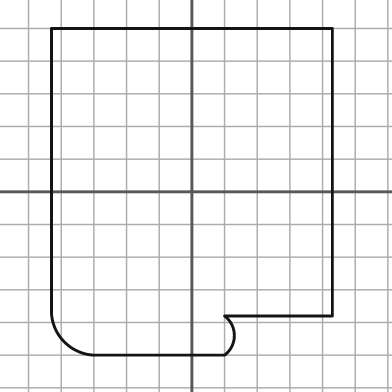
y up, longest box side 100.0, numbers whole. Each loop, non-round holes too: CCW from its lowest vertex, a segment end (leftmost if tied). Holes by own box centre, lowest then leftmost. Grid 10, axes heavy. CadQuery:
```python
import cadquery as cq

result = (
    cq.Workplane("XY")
    .moveTo(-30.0, -50.0)
    .lineTo(10.0, -50.0)
    .threePointArc((13.0, -44.0), (10.0, -38.0))
    .lineTo(43.0, -38.0)
    .lineTo(43.0, 50.0)
    .lineTo(-43.0, 50.0)
    .lineTo(-43.0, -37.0)
    .threePointArc((-39.0, -46.0), (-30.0, -50.0))
    .close()
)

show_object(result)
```